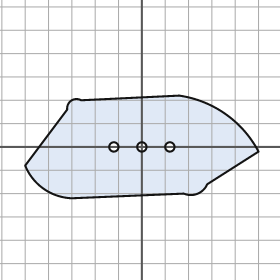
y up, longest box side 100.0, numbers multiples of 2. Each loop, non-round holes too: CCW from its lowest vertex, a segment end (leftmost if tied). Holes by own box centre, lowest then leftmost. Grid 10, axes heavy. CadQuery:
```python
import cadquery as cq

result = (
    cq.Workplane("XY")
    .moveTo(-30.0, -22.0)
    .lineTo(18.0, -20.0)
    .threePointArc((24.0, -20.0), (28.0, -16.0))
    .lineTo(50.0, -2.0)
    .threePointArc((36.0, 14.0), (16.0, 22.0))
    .lineTo(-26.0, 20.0)
    .threePointArc((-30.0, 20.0), (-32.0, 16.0))
    .lineTo(-50.0, -8.0)
    .threePointArc((-42.0, -18.0), (-30.0, -22.0))
    .close()
    .moveTo(-12.0, 0.0)
    .circle(2.0)
    .moveTo(0.0, 0.0)
    .circle(2.0)
    .moveTo(12.0, 0.0)
    .circle(2.0)
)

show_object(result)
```